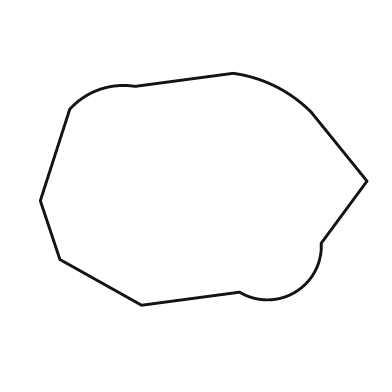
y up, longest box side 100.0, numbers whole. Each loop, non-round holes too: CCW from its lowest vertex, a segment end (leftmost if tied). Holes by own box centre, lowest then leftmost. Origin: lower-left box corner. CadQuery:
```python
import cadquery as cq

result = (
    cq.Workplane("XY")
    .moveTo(31.0, 0.0)
    .lineTo(61.0, 4.0)
    .threePointArc((78.0, 4.0), (86.0, 19.0))
    .lineTo(100.0, 38.0)
    .lineTo(83.0, 59.0)
    .threePointArc((72.0, 67.0), (59.0, 71.0))
    .lineTo(29.0, 67.0)
    .threePointArc((18.0, 66.0), (9.0, 60.0))
    .lineTo(0.0, 32.0)
    .lineTo(6.0, 14.0)
    .close()
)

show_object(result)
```